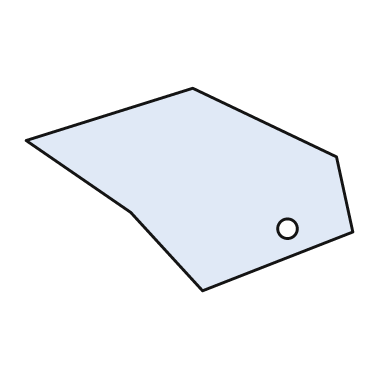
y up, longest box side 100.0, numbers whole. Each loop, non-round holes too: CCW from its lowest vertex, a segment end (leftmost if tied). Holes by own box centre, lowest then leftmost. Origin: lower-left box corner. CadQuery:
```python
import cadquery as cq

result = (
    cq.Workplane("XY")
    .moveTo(54.0, 0.0)
    .lineTo(100.0, 18.0)
    .lineTo(95.0, 41.0)
    .lineTo(51.0, 62.0)
    .lineTo(0.0, 46.0)
    .lineTo(32.0, 24.0)
    .close()
    .moveTo(80.0, 19.0)
    .circle(3.0)
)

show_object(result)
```